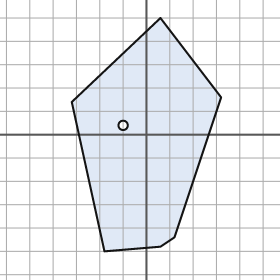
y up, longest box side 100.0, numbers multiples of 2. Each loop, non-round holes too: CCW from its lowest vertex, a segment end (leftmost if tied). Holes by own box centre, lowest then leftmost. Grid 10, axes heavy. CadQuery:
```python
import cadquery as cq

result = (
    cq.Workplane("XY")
    .moveTo(-18.0, -50.0)
    .lineTo(6.0, -48.0)
    .lineTo(12.0, -44.0)
    .lineTo(32.0, 16.0)
    .lineTo(6.0, 50.0)
    .lineTo(-32.0, 14.0)
    .close()
    .moveTo(-10.0, 4.0)
    .circle(2.0)
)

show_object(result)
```